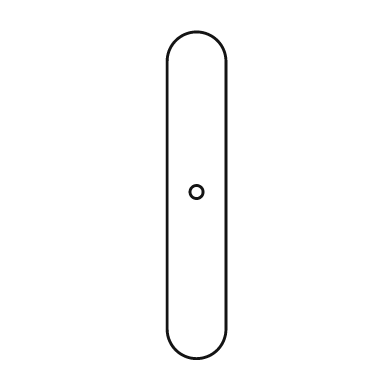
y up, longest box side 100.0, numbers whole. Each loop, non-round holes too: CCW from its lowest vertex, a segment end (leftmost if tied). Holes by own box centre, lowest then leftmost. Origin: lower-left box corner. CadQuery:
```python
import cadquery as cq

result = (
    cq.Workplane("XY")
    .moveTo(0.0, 9.0)
    .threePointArc((9.0, 0.0), (18.0, 9.0))
    .lineTo(18.0, 91.0)
    .threePointArc((9.0, 100.0), (0.0, 91.0))
    .close()
    .moveTo(9.0, 51.0)
    .circle(2.0)
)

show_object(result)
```